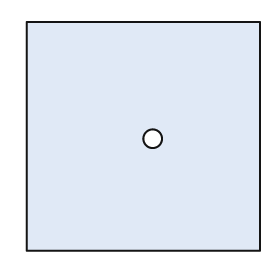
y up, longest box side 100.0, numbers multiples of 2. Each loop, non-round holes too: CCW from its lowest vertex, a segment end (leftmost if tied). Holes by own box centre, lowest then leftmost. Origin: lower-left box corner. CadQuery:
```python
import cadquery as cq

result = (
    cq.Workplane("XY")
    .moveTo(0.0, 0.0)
    .lineTo(100.0, 0.0)
    .lineTo(100.0, 98.0)
    .lineTo(0.0, 98.0)
    .close()
    .moveTo(54.0, 48.0)
    .circle(4.0)
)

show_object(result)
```